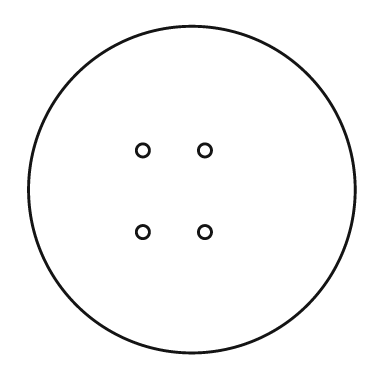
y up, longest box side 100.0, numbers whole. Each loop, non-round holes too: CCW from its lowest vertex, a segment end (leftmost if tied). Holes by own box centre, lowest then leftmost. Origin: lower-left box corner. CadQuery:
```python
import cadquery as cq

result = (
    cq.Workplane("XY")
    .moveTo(50.0, 50.0)
    .circle(50.0)
    .moveTo(35.0, 37.0)
    .circle(2.0)
    .moveTo(54.0, 37.0)
    .circle(2.0)
    .moveTo(35.0, 62.0)
    .circle(2.0)
    .moveTo(54.0, 62.0)
    .circle(2.0)
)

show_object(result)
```